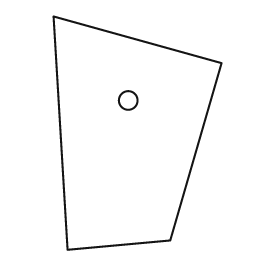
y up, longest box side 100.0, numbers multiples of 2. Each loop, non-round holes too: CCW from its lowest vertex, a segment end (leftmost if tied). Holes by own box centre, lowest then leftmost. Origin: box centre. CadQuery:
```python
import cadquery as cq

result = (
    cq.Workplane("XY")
    .moveTo(-30.0, -50.0)
    .lineTo(14.0, -46.0)
    .lineTo(36.0, 30.0)
    .lineTo(-36.0, 50.0)
    .close()
    .moveTo(-4.0, 14.0)
    .circle(4.0)
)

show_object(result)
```